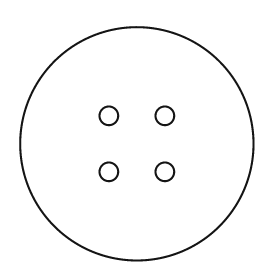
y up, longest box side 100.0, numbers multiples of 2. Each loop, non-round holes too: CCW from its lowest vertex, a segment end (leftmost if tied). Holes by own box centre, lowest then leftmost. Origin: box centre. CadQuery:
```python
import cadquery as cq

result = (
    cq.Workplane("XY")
    .moveTo(0.0, 0.0)
    .circle(50.0)
    .moveTo(-12.0, -12.0)
    .circle(4.0)
    .moveTo(12.0, -12.0)
    .circle(4.0)
    .moveTo(-12.0, 12.0)
    .circle(4.0)
    .moveTo(12.0, 12.0)
    .circle(4.0)
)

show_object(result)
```